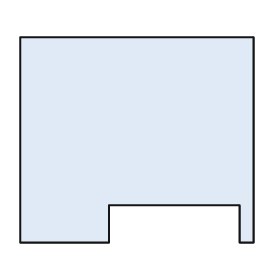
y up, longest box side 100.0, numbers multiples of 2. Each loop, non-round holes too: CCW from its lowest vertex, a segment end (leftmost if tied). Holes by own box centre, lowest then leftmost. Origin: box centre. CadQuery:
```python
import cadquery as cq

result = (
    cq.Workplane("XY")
    .moveTo(-50.0, -44.0)
    .lineTo(-12.0, -44.0)
    .lineTo(-12.0, -28.0)
    .lineTo(44.0, -28.0)
    .lineTo(44.0, -44.0)
    .lineTo(50.0, -44.0)
    .lineTo(50.0, 44.0)
    .lineTo(-50.0, 44.0)
    .close()
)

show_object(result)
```